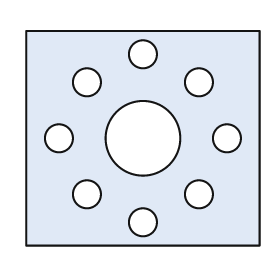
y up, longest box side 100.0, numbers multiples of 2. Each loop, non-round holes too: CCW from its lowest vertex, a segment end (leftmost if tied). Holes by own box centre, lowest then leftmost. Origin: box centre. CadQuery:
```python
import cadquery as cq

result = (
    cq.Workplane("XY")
    .moveTo(-50.0, -46.0)
    .lineTo(50.0, -46.0)
    .lineTo(50.0, 46.0)
    .lineTo(-50.0, 46.0)
    .close()
    .moveTo(0.0, -36.0)
    .circle(6.0)
    .moveTo(-24.0, -24.0)
    .circle(6.0)
    .moveTo(24.0, -24.0)
    .circle(6.0)
    .moveTo(-36.0, 0.0)
    .circle(6.0)
    .moveTo(0.0, 0.0)
    .circle(16.0)
    .moveTo(36.0, 0.0)
    .circle(6.0)
    .moveTo(-24.0, 24.0)
    .circle(6.0)
    .moveTo(24.0, 24.0)
    .circle(6.0)
    .moveTo(0.0, 36.0)
    .circle(6.0)
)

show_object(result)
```